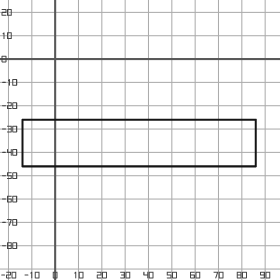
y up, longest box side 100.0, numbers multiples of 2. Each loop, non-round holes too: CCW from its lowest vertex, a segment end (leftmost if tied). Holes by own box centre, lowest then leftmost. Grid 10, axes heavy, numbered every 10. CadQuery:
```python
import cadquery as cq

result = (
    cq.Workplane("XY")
    .moveTo(-14.0, -46.0)
    .lineTo(86.0, -46.0)
    .lineTo(86.0, -26.0)
    .lineTo(-14.0, -26.0)
    .close()
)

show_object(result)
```